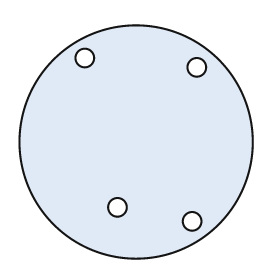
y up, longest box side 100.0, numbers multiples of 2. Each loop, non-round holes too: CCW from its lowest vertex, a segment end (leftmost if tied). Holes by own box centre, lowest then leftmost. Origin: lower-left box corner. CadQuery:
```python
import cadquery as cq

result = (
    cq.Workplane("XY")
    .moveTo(50.0, 50.0)
    .circle(50.0)
    .moveTo(74.0, 16.0)
    .circle(4.0)
    .moveTo(42.0, 22.0)
    .circle(4.0)
    .moveTo(76.0, 82.0)
    .circle(4.0)
    .moveTo(28.0, 86.0)
    .circle(4.0)
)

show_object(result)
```